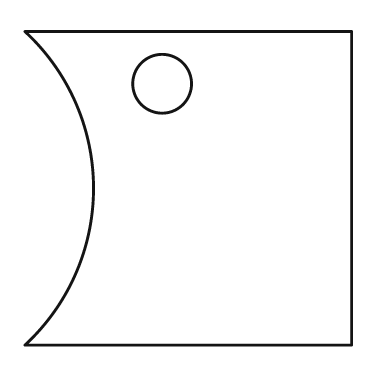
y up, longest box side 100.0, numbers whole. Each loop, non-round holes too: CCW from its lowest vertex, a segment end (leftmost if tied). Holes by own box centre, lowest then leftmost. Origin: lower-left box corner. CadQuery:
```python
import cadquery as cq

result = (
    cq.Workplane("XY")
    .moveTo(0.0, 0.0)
    .lineTo(100.0, 0.0)
    .lineTo(100.0, 96.0)
    .lineTo(0.0, 96.0)
    .threePointArc((21.0, 48.0), (0.0, 0.0))
    .close()
    .moveTo(42.0, 80.0)
    .circle(9.0)
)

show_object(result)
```